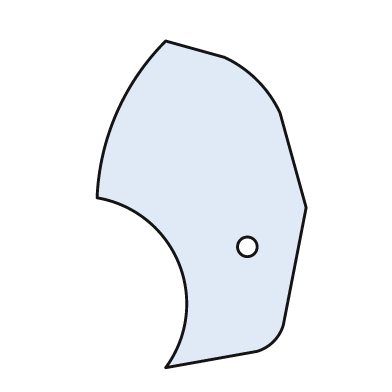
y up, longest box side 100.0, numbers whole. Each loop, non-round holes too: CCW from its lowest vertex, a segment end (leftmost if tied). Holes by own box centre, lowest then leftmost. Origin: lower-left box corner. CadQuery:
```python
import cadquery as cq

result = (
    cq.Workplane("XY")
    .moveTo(21.0, 0.0)
    .lineTo(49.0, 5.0)
    .threePointArc((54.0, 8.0), (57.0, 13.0))
    .lineTo(64.0, 49.0)
    .lineTo(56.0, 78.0)
    .threePointArc((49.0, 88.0), (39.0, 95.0))
    .lineTo(21.0, 100.0)
    .threePointArc((6.0, 78.0), (0.0, 52.0))
    .threePointArc((25.0, 32.0), (21.0, 0.0))
    .close()
    .moveTo(46.0, 37.0)
    .circle(3.0)
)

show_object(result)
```